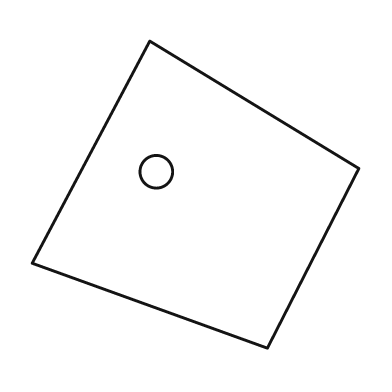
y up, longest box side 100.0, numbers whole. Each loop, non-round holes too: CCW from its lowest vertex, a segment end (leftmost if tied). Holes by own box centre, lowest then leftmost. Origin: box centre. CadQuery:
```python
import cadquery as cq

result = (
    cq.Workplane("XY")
    .moveTo(22.0, -47.0)
    .lineTo(50.0, 8.0)
    .lineTo(-14.0, 47.0)
    .lineTo(-50.0, -21.0)
    .close()
    .moveTo(-12.0, 7.0)
    .circle(5.0)
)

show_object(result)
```